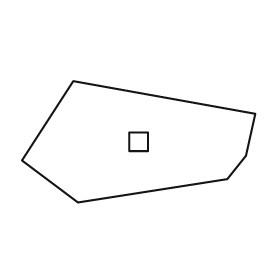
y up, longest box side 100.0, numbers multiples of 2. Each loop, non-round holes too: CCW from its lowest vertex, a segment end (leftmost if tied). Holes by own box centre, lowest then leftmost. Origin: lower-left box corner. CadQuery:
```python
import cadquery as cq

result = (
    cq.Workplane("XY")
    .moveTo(24.0, 0.0)
    .lineTo(88.0, 10.0)
    .lineTo(96.0, 20.0)
    .lineTo(100.0, 38.0)
    .lineTo(22.0, 52.0)
    .lineTo(0.0, 18.0)
    .close()
    .moveTo(46.0, 22.0)
    .lineTo(54.0, 22.0)
    .lineTo(54.0, 30.0)
    .lineTo(46.0, 30.0)
    .close()
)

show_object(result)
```